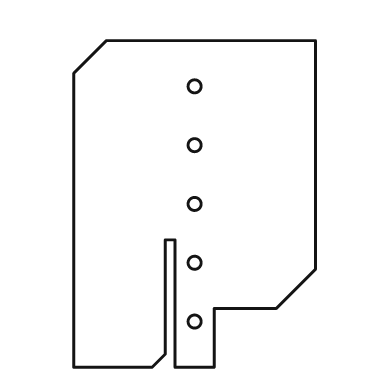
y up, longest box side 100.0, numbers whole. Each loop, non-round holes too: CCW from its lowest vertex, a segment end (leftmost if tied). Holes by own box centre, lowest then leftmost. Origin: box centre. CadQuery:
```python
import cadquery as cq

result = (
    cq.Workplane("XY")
    .moveTo(-37.0, -50.0)
    .lineTo(-13.0, -50.0)
    .lineTo(-9.0, -46.0)
    .lineTo(-9.0, -11.0)
    .lineTo(-6.0, -11.0)
    .lineTo(-6.0, -50.0)
    .lineTo(6.0, -50.0)
    .lineTo(6.0, -32.0)
    .lineTo(25.0, -32.0)
    .lineTo(37.0, -20.0)
    .lineTo(37.0, 50.0)
    .lineTo(-27.0, 50.0)
    .lineTo(-37.0, 40.0)
    .close()
    .moveTo(0.0, -36.0)
    .circle(2.0)
    .moveTo(0.0, -18.0)
    .circle(2.0)
    .moveTo(0.0, 0.0)
    .circle(2.0)
    .moveTo(0.0, 18.0)
    .circle(2.0)
    .moveTo(0.0, 36.0)
    .circle(2.0)
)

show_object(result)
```